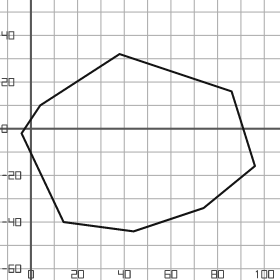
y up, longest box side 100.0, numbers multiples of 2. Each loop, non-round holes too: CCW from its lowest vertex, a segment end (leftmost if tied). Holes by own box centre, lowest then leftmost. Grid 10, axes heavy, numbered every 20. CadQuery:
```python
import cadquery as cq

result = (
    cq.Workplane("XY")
    .moveTo(44.0, -44.0)
    .lineTo(74.0, -34.0)
    .lineTo(96.0, -16.0)
    .lineTo(86.0, 16.0)
    .lineTo(38.0, 32.0)
    .lineTo(4.0, 10.0)
    .lineTo(-4.0, -2.0)
    .lineTo(14.0, -40.0)
    .close()
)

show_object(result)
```